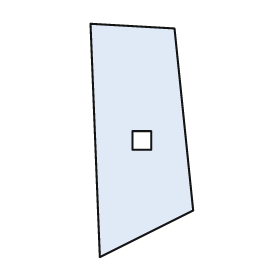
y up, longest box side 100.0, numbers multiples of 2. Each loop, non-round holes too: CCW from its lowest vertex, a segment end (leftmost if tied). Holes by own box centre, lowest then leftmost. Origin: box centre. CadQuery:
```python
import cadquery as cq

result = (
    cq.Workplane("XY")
    .moveTo(-18.0, -50.0)
    .lineTo(22.0, -30.0)
    .lineTo(14.0, 48.0)
    .lineTo(-22.0, 50.0)
    .close()
    .moveTo(-4.0, -4.0)
    .lineTo(4.0, -4.0)
    .lineTo(4.0, 4.0)
    .lineTo(-4.0, 4.0)
    .close()
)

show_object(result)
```